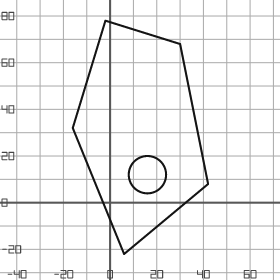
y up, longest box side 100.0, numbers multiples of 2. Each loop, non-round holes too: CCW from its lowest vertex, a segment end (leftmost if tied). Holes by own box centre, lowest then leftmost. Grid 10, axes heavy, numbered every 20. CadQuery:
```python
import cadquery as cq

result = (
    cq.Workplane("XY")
    .moveTo(6.0, -22.0)
    .lineTo(42.0, 8.0)
    .lineTo(30.0, 68.0)
    .lineTo(-2.0, 78.0)
    .lineTo(-16.0, 32.0)
    .close()
    .moveTo(16.0, 12.0)
    .circle(8.0)
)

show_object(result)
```